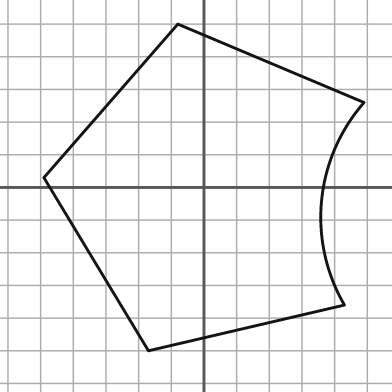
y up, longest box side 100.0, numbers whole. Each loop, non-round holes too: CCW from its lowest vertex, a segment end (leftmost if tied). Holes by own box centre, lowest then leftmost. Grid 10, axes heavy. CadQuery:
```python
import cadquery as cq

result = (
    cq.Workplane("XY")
    .moveTo(-17.0, -50.0)
    .lineTo(43.0, -36.0)
    .threePointArc((36.0, -4.0), (49.0, 26.0))
    .lineTo(-8.0, 50.0)
    .lineTo(-49.0, 3.0)
    .close()
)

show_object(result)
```